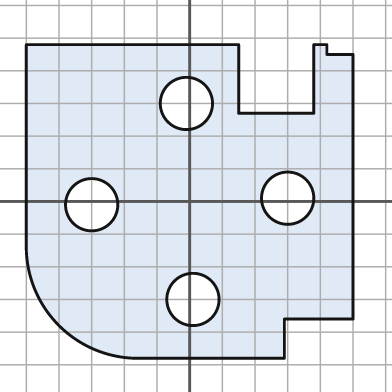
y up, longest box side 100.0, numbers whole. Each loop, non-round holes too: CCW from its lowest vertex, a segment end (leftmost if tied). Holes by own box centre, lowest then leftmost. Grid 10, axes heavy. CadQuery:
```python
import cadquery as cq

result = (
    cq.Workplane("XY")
    .moveTo(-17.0, -48.0)
    .lineTo(29.0, -48.0)
    .lineTo(29.0, -36.0)
    .lineTo(50.0, -36.0)
    .lineTo(50.0, 45.0)
    .lineTo(42.0, 45.0)
    .lineTo(42.0, 48.0)
    .lineTo(38.0, 48.0)
    .lineTo(38.0, 27.0)
    .lineTo(15.0, 27.0)
    .lineTo(15.0, 48.0)
    .lineTo(-50.0, 48.0)
    .lineTo(-50.0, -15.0)
    .threePointArc((-40.0, -38.0), (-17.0, -48.0))
    .close()
    .moveTo(1.0, -30.0)
    .circle(8.0)
    .moveTo(-30.0, -1.0)
    .circle(8.0)
    .moveTo(30.0, 1.0)
    .circle(8.0)
    .moveTo(-1.0, 30.0)
    .circle(8.0)
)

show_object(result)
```